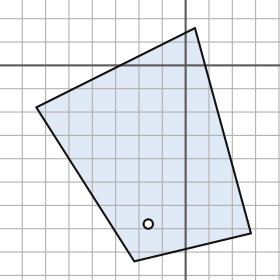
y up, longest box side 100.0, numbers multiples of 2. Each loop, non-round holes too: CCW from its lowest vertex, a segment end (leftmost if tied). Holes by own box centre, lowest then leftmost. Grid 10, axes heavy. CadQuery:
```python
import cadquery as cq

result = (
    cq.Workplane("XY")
    .moveTo(-22.0, -84.0)
    .lineTo(28.0, -72.0)
    .lineTo(4.0, 16.0)
    .lineTo(-64.0, -18.0)
    .close()
    .moveTo(-16.0, -68.0)
    .circle(2.0)
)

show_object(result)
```